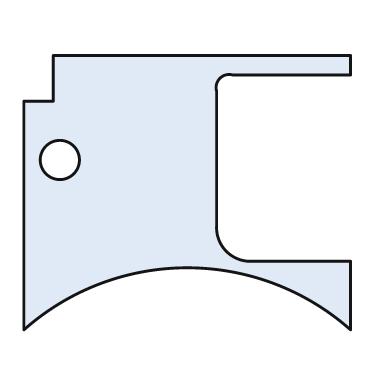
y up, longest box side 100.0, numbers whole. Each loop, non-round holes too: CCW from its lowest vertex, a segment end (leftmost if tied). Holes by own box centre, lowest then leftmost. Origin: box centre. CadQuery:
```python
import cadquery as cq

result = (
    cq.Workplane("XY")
    .moveTo(-50.0, -42.0)
    .threePointArc((0.0, -23.0), (50.0, -42.0))
    .lineTo(50.0, -21.0)
    .lineTo(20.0, -21.0)
    .threePointArc((12.0, -18.0), (9.0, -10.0))
    .lineTo(9.0, 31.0)
    .threePointArc((10.0, 35.0), (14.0, 36.0))
    .lineTo(50.0, 36.0)
    .lineTo(50.0, 42.0)
    .lineTo(-41.0, 42.0)
    .lineTo(-41.0, 28.0)
    .lineTo(-50.0, 28.0)
    .close()
    .moveTo(-39.0, 10.0)
    .circle(6.0)
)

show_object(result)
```